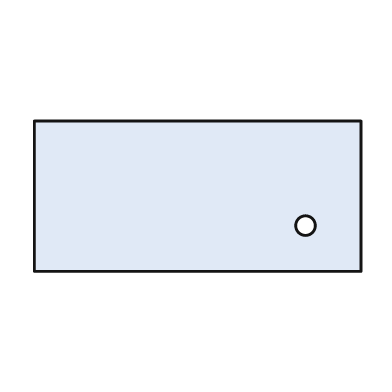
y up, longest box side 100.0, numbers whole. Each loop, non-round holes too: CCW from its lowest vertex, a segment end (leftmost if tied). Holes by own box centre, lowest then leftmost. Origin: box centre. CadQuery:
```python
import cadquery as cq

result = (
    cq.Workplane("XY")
    .moveTo(-50.0, -23.0)
    .lineTo(50.0, -23.0)
    .lineTo(50.0, 23.0)
    .lineTo(-50.0, 23.0)
    .close()
    .moveTo(33.0, -9.0)
    .circle(3.0)
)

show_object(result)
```